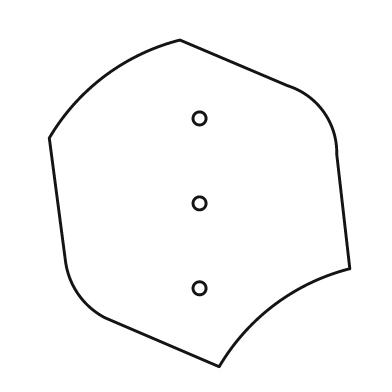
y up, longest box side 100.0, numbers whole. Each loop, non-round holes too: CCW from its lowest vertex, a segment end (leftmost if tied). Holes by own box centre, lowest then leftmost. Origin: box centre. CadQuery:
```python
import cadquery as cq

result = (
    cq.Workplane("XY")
    .moveTo(6.0, -50.0)
    .threePointArc((23.0, -31.0), (46.0, -20.0))
    .lineTo(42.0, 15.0)
    .threePointArc((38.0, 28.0), (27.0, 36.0))
    .lineTo(-6.0, 50.0)
    .threePointArc((-29.0, 39.0), (-46.0, 20.0))
    .lineTo(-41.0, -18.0)
    .threePointArc((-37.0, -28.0), (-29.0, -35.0))
    .close()
    .moveTo(0.0, -26.0)
    .circle(2.0)
    .moveTo(0.0, 0.0)
    .circle(2.0)
    .moveTo(0.0, 26.0)
    .circle(2.0)
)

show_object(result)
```